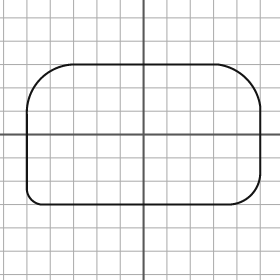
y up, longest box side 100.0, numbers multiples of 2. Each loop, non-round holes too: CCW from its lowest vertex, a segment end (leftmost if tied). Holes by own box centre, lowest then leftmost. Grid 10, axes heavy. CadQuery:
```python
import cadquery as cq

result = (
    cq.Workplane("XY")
    .moveTo(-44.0, -30.0)
    .lineTo(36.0, -30.0)
    .threePointArc((46.0, -26.0), (50.0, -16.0))
    .lineTo(50.0, 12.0)
    .threePointArc((44.0, 24.0), (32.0, 30.0))
    .lineTo(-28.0, 30.0)
    .threePointArc((-44.0, 24.0), (-50.0, 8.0))
    .lineTo(-50.0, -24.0)
    .threePointArc((-48.0, -28.0), (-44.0, -30.0))
    .close()
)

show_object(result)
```